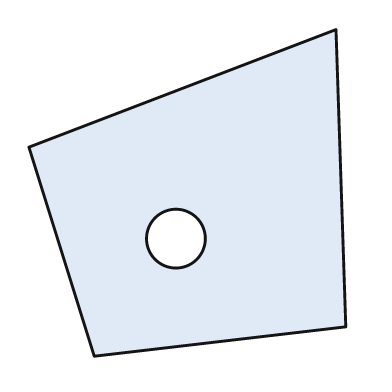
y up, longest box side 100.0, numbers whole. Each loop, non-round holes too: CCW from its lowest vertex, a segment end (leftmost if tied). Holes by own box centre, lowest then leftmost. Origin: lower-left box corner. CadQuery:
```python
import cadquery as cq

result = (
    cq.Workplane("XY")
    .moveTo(20.0, 0.0)
    .lineTo(97.0, 9.0)
    .lineTo(94.0, 100.0)
    .lineTo(0.0, 64.0)
    .close()
    .moveTo(45.0, 36.0)
    .circle(9.0)
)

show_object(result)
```